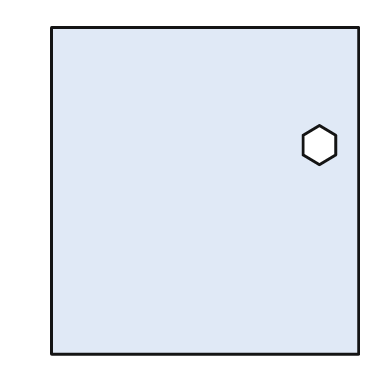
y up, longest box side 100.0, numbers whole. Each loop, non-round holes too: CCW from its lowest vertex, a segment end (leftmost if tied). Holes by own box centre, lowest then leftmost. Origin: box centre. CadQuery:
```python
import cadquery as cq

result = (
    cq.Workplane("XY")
    .moveTo(-47.0, -50.0)
    .lineTo(47.0, -50.0)
    .lineTo(47.0, 50.0)
    .lineTo(-47.0, 50.0)
    .close()
    .moveTo(35.0, 8.0)
    .lineTo(40.0, 11.0)
    .lineTo(40.0, 17.0)
    .lineTo(35.0, 20.0)
    .lineTo(30.0, 17.0)
    .lineTo(30.0, 11.0)
    .close()
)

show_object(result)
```